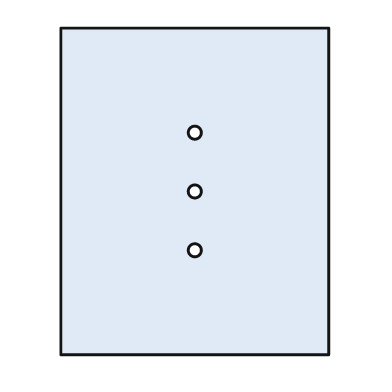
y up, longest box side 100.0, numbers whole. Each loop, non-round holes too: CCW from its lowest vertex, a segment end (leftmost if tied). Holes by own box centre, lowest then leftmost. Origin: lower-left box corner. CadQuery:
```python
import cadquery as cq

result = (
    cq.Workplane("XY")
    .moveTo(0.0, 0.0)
    .lineTo(82.0, 0.0)
    .lineTo(82.0, 100.0)
    .lineTo(0.0, 100.0)
    .close()
    .moveTo(41.0, 32.0)
    .circle(2.0)
    .moveTo(41.0, 50.0)
    .circle(2.0)
    .moveTo(41.0, 68.0)
    .circle(2.0)
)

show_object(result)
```